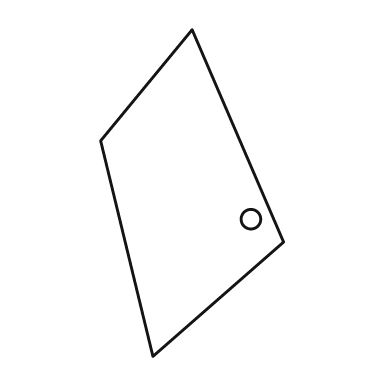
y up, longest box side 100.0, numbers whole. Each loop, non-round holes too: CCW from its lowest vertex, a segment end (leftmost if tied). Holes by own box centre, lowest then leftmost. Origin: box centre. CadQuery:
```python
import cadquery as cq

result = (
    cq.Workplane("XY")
    .moveTo(-12.0, -50.0)
    .lineTo(28.0, -15.0)
    .lineTo(0.0, 50.0)
    .lineTo(-28.0, 16.0)
    .close()
    .moveTo(18.0, -8.0)
    .circle(3.0)
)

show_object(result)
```